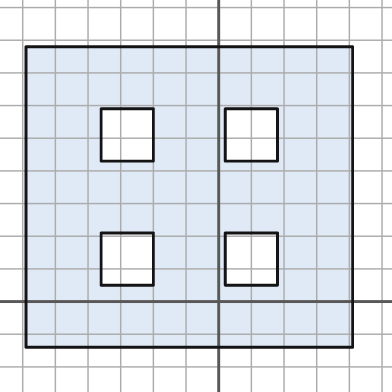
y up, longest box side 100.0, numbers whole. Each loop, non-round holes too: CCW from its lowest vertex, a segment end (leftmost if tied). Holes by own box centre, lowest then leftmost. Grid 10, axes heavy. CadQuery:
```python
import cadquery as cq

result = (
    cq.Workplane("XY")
    .moveTo(-59.0, -14.0)
    .lineTo(41.0, -14.0)
    .lineTo(41.0, 78.0)
    .lineTo(-59.0, 78.0)
    .close()
    .moveTo(-36.0, 5.0)
    .lineTo(-20.0, 5.0)
    .lineTo(-20.0, 21.0)
    .lineTo(-36.0, 21.0)
    .close()
    .moveTo(2.0, 5.0)
    .lineTo(18.0, 5.0)
    .lineTo(18.0, 21.0)
    .lineTo(2.0, 21.0)
    .close()
    .moveTo(-36.0, 43.0)
    .lineTo(-20.0, 43.0)
    .lineTo(-20.0, 59.0)
    .lineTo(-36.0, 59.0)
    .close()
    .moveTo(2.0, 43.0)
    .lineTo(18.0, 43.0)
    .lineTo(18.0, 59.0)
    .lineTo(2.0, 59.0)
    .close()
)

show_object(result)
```